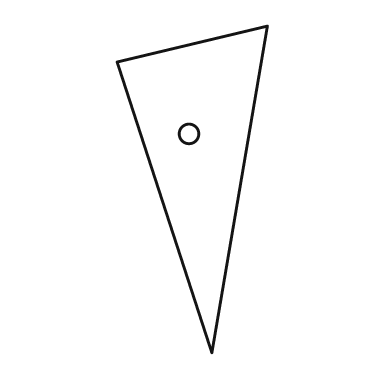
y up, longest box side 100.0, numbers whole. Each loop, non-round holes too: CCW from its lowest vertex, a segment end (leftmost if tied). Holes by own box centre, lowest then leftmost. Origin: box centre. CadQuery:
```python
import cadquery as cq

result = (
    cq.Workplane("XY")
    .moveTo(6.0, -50.0)
    .lineTo(23.0, 50.0)
    .lineTo(-23.0, 39.0)
    .close()
    .moveTo(-1.0, 17.0)
    .circle(3.0)
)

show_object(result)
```